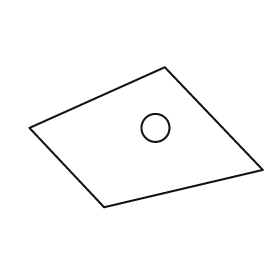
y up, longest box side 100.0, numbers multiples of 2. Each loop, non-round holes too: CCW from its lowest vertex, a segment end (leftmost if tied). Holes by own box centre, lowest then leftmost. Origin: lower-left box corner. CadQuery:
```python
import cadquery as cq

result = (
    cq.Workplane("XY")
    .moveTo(32.0, 0.0)
    .lineTo(100.0, 16.0)
    .lineTo(58.0, 60.0)
    .lineTo(0.0, 34.0)
    .close()
    .moveTo(54.0, 34.0)
    .circle(6.0)
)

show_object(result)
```